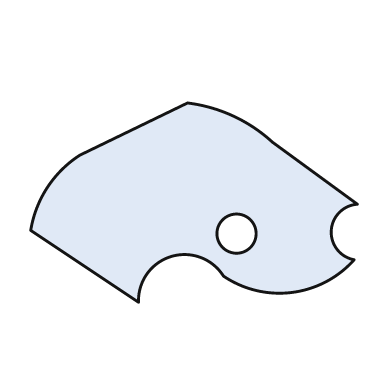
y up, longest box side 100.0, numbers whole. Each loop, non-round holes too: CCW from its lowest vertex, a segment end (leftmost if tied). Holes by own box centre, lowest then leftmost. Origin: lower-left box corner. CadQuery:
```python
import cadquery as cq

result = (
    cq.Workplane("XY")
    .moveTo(33.0, 0.0)
    .threePointArc((43.0, 14.0), (59.0, 8.0))
    .threePointArc((80.0, 3.0), (99.0, 13.0))
    .threePointArc((92.0, 22.0), (100.0, 30.0))
    .lineTo(74.0, 49.0)
    .threePointArc((62.0, 57.0), (48.0, 61.0))
    .lineTo(15.0, 45.0)
    .threePointArc((5.0, 35.0), (0.0, 22.0))
    .close()
    .moveTo(63.0, 21.0)
    .circle(6.0)
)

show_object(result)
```